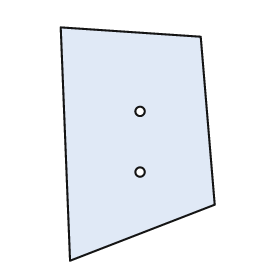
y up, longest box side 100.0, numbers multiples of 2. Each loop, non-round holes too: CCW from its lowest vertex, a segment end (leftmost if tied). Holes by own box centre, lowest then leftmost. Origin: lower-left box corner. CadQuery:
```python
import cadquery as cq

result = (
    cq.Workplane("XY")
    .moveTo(4.0, 0.0)
    .lineTo(66.0, 24.0)
    .lineTo(60.0, 96.0)
    .lineTo(0.0, 100.0)
    .close()
    .moveTo(34.0, 38.0)
    .circle(2.0)
    .moveTo(34.0, 64.0)
    .circle(2.0)
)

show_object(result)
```